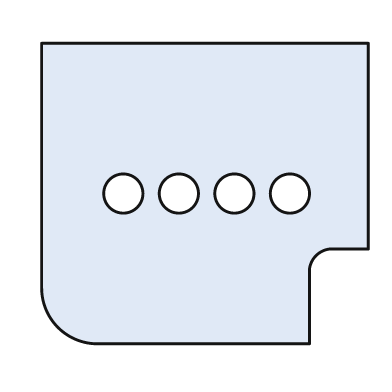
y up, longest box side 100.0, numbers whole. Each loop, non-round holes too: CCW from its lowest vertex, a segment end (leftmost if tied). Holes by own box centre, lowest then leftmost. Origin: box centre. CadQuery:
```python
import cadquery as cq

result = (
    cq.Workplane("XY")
    .moveTo(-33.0, -46.0)
    .lineTo(32.0, -46.0)
    .lineTo(32.0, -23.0)
    .threePointArc((34.0, -19.0), (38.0, -17.0))
    .lineTo(50.0, -17.0)
    .lineTo(50.0, 46.0)
    .lineTo(-50.0, 46.0)
    .lineTo(-50.0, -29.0)
    .threePointArc((-45.0, -41.0), (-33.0, -46.0))
    .close()
    .moveTo(-25.0, 0.0)
    .circle(6.0)
    .moveTo(-8.0, 0.0)
    .circle(6.0)
    .moveTo(9.0, 0.0)
    .circle(6.0)
    .moveTo(26.0, 0.0)
    .circle(6.0)
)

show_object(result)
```